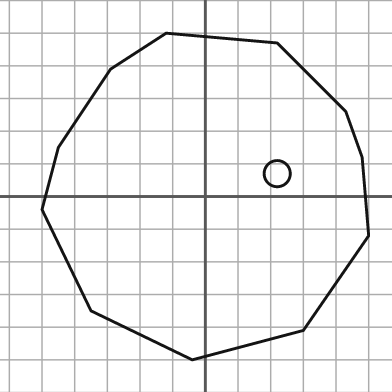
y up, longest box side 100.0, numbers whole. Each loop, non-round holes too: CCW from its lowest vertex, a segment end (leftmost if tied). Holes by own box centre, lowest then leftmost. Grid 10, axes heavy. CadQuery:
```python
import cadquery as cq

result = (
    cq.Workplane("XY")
    .moveTo(-4.0, -50.0)
    .lineTo(30.0, -41.0)
    .lineTo(50.0, -12.0)
    .lineTo(48.0, 12.0)
    .lineTo(43.0, 26.0)
    .lineTo(22.0, 47.0)
    .lineTo(-12.0, 50.0)
    .lineTo(-29.0, 39.0)
    .lineTo(-45.0, 15.0)
    .lineTo(-50.0, -4.0)
    .lineTo(-35.0, -35.0)
    .close()
    .moveTo(22.0, 7.0)
    .circle(4.0)
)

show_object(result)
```